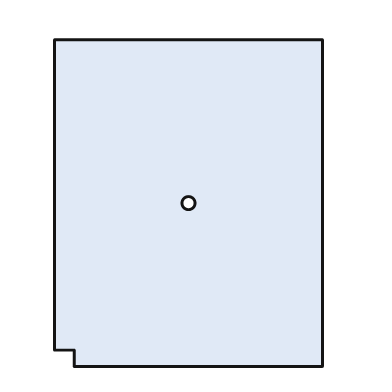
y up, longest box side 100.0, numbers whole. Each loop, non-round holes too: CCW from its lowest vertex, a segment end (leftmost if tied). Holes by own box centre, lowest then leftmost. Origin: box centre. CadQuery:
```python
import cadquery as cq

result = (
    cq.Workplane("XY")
    .moveTo(-35.0, -50.0)
    .lineTo(41.0, -50.0)
    .lineTo(41.0, 50.0)
    .lineTo(-41.0, 50.0)
    .lineTo(-41.0, -45.0)
    .lineTo(-35.0, -45.0)
    .close()
    .moveTo(0.0, 0.0)
    .circle(2.0)
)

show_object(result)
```